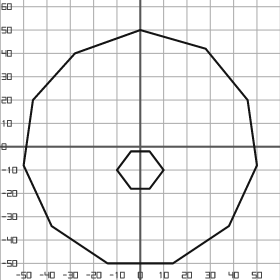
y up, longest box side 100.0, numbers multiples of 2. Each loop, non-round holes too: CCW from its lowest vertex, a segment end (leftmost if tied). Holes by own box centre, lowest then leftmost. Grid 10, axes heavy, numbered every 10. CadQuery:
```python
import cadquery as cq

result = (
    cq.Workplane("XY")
    .moveTo(-14.0, -50.0)
    .lineTo(14.0, -50.0)
    .lineTo(38.0, -34.0)
    .lineTo(50.0, -8.0)
    .lineTo(46.0, 20.0)
    .lineTo(28.0, 42.0)
    .lineTo(0.0, 50.0)
    .lineTo(-28.0, 40.0)
    .lineTo(-46.0, 20.0)
    .lineTo(-50.0, -8.0)
    .lineTo(-38.0, -34.0)
    .close()
    .moveTo(-4.0, -18.0)
    .lineTo(4.0, -18.0)
    .lineTo(10.0, -10.0)
    .lineTo(4.0, -2.0)
    .lineTo(-4.0, -2.0)
    .lineTo(-10.0, -10.0)
    .close()
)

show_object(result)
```